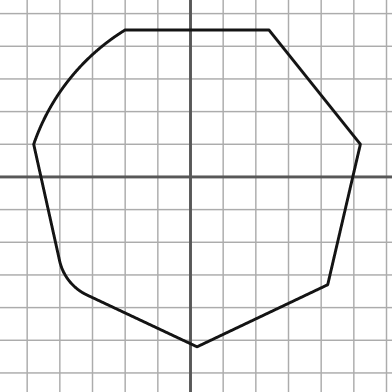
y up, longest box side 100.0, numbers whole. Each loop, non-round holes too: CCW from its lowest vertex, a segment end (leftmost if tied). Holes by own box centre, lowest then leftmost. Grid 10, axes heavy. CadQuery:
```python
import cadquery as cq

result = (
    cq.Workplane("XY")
    .moveTo(2.0, -52.0)
    .lineTo(42.0, -33.0)
    .lineTo(52.0, 10.0)
    .lineTo(24.0, 45.0)
    .lineTo(-20.0, 45.0)
    .threePointArc((-37.0, 30.0), (-48.0, 10.0))
    .lineTo(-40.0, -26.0)
    .threePointArc((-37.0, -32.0), (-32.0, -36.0))
    .close()
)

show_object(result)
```